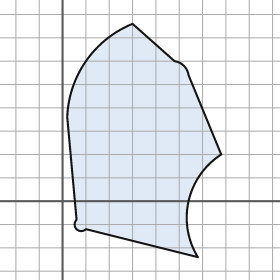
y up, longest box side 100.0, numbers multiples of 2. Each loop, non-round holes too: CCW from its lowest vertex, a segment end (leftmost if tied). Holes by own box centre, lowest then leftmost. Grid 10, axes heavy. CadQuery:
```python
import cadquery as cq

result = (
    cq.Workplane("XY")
    .moveTo(58.0, -24.0)
    .threePointArc((54.0, 0.0), (68.0, 20.0))
    .lineTo(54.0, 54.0)
    .threePointArc((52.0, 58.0), (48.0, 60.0))
    .lineTo(30.0, 76.0)
    .threePointArc((10.0, 60.0), (2.0, 36.0))
    .lineTo(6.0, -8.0)
    .threePointArc((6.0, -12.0), (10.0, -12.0))
    .close()
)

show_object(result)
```